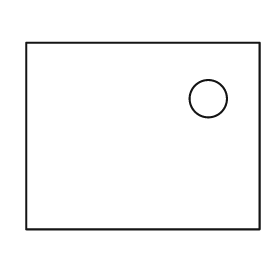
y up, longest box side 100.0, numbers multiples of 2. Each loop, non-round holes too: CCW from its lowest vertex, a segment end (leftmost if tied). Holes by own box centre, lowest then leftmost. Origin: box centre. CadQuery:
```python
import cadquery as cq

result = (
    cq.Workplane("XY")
    .moveTo(-50.0, -40.0)
    .lineTo(50.0, -40.0)
    .lineTo(50.0, 40.0)
    .lineTo(-50.0, 40.0)
    .close()
    .moveTo(28.0, 16.0)
    .circle(8.0)
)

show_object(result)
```